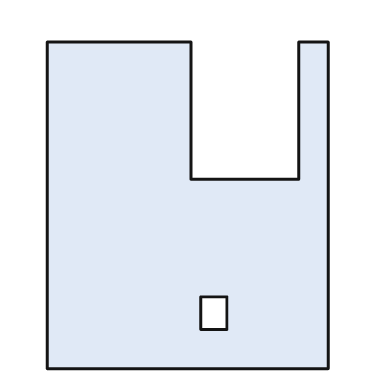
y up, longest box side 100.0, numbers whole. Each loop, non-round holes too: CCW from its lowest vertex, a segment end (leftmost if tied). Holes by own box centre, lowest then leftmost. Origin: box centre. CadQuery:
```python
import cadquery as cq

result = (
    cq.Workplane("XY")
    .moveTo(-43.0, -50.0)
    .lineTo(43.0, -50.0)
    .lineTo(43.0, 50.0)
    .lineTo(34.0, 50.0)
    .lineTo(34.0, 8.0)
    .lineTo(1.0, 8.0)
    .lineTo(1.0, 50.0)
    .lineTo(-43.0, 50.0)
    .close()
    .moveTo(4.0, -38.0)
    .lineTo(12.0, -38.0)
    .lineTo(12.0, -28.0)
    .lineTo(4.0, -28.0)
    .close()
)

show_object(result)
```